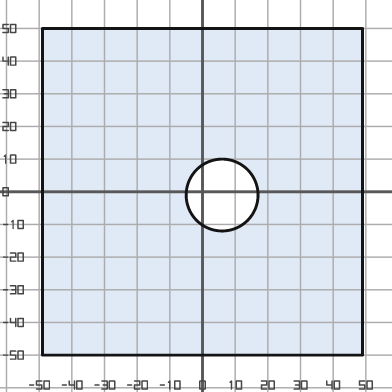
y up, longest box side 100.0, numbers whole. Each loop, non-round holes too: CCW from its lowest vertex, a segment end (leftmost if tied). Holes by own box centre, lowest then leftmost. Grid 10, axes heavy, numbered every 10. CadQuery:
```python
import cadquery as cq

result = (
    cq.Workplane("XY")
    .moveTo(-49.0, -50.0)
    .lineTo(49.0, -50.0)
    .lineTo(49.0, 50.0)
    .lineTo(-49.0, 50.0)
    .close()
    .moveTo(6.0, -1.0)
    .circle(11.0)
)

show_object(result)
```